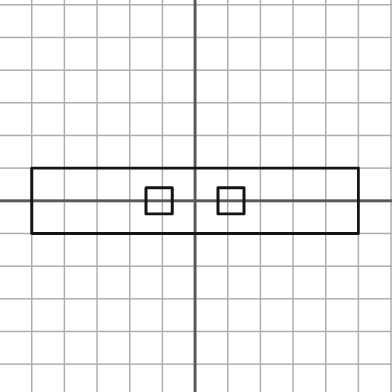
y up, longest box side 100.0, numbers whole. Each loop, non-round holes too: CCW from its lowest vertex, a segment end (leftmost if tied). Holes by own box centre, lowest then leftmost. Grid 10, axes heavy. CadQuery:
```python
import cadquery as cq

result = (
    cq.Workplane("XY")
    .moveTo(-50.0, -10.0)
    .lineTo(50.0, -10.0)
    .lineTo(50.0, 10.0)
    .lineTo(-50.0, 10.0)
    .close()
    .moveTo(-15.0, -4.0)
    .lineTo(-7.0, -4.0)
    .lineTo(-7.0, 4.0)
    .lineTo(-15.0, 4.0)
    .close()
    .moveTo(7.0, -4.0)
    .lineTo(15.0, -4.0)
    .lineTo(15.0, 4.0)
    .lineTo(7.0, 4.0)
    .close()
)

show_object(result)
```